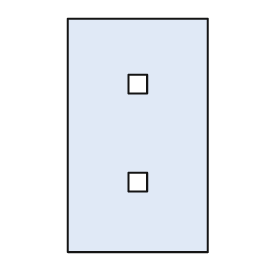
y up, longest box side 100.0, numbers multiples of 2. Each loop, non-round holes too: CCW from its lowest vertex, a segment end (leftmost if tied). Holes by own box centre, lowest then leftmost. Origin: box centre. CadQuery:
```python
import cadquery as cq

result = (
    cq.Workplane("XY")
    .moveTo(-30.0, -50.0)
    .lineTo(30.0, -50.0)
    .lineTo(30.0, 50.0)
    .lineTo(-30.0, 50.0)
    .close()
    .moveTo(-4.0, -24.0)
    .lineTo(4.0, -24.0)
    .lineTo(4.0, -16.0)
    .lineTo(-4.0, -16.0)
    .close()
    .moveTo(-4.0, 18.0)
    .lineTo(4.0, 18.0)
    .lineTo(4.0, 26.0)
    .lineTo(-4.0, 26.0)
    .close()
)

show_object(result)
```